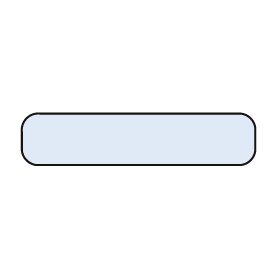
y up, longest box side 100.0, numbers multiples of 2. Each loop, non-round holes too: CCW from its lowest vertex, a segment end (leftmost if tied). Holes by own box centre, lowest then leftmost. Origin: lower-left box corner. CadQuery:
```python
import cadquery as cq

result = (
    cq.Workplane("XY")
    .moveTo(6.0, 0.0)
    .lineTo(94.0, 0.0)
    .threePointArc((98.0, 2.0), (100.0, 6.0))
    .lineTo(100.0, 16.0)
    .threePointArc((98.0, 20.0), (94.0, 22.0))
    .lineTo(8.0, 22.0)
    .threePointArc((2.0, 20.0), (0.0, 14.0))
    .lineTo(0.0, 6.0)
    .threePointArc((2.0, 2.0), (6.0, 0.0))
    .close()
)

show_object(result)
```